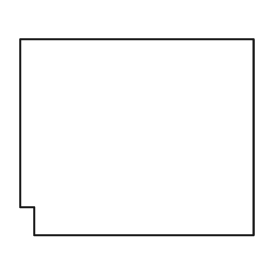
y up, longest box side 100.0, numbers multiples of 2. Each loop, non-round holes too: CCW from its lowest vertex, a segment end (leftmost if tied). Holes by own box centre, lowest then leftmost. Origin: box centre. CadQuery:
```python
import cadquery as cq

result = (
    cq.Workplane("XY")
    .moveTo(-44.0, -42.0)
    .lineTo(50.0, -42.0)
    .lineTo(50.0, 42.0)
    .lineTo(-50.0, 42.0)
    .lineTo(-50.0, -30.0)
    .lineTo(-44.0, -30.0)
    .close()
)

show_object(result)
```